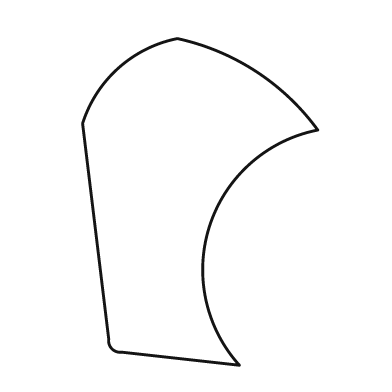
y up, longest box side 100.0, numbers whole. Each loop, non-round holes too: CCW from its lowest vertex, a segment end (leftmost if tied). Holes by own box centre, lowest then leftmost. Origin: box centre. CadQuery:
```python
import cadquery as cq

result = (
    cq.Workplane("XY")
    .moveTo(12.0, -50.0)
    .threePointArc((3.0, -7.0), (36.0, 22.0))
    .threePointArc((17.0, 40.0), (-7.0, 50.0))
    .threePointArc((-25.0, 41.0), (-36.0, 24.0))
    .lineTo(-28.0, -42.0)
    .threePointArc((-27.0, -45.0), (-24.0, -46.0))
    .close()
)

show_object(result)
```